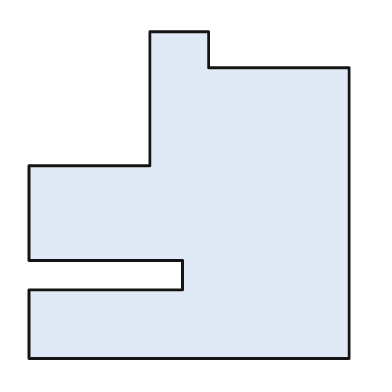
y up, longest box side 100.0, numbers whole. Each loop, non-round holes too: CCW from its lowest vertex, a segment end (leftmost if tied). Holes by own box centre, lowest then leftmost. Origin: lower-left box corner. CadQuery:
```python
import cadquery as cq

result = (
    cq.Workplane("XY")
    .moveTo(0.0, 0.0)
    .lineTo(98.0, 0.0)
    .lineTo(98.0, 89.0)
    .lineTo(55.0, 89.0)
    .lineTo(55.0, 100.0)
    .lineTo(37.0, 100.0)
    .lineTo(37.0, 59.0)
    .lineTo(0.0, 59.0)
    .lineTo(0.0, 30.0)
    .lineTo(47.0, 30.0)
    .lineTo(47.0, 21.0)
    .lineTo(0.0, 21.0)
    .close()
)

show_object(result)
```